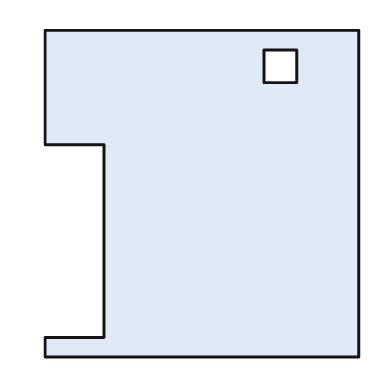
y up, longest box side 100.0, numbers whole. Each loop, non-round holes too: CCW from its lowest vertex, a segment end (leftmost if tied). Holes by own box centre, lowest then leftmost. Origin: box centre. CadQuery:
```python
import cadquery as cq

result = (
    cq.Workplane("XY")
    .moveTo(-48.0, -50.0)
    .lineTo(48.0, -50.0)
    .lineTo(48.0, 50.0)
    .lineTo(-48.0, 50.0)
    .lineTo(-48.0, 15.0)
    .lineTo(-30.0, 15.0)
    .lineTo(-30.0, -44.0)
    .lineTo(-48.0, -44.0)
    .close()
    .moveTo(19.0, 34.0)
    .lineTo(29.0, 34.0)
    .lineTo(29.0, 44.0)
    .lineTo(19.0, 44.0)
    .close()
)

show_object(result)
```